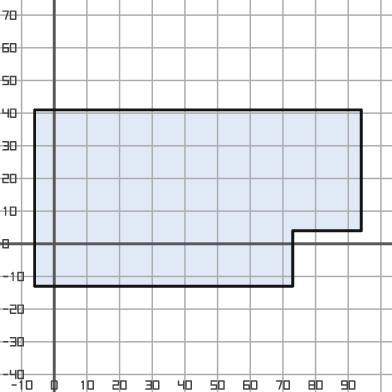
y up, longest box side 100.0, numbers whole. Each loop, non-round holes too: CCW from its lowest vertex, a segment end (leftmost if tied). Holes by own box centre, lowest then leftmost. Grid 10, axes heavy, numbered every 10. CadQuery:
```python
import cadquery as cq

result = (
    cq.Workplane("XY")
    .moveTo(-6.0, -13.0)
    .lineTo(73.0, -13.0)
    .lineTo(73.0, 4.0)
    .lineTo(94.0, 4.0)
    .lineTo(94.0, 41.0)
    .lineTo(-6.0, 41.0)
    .close()
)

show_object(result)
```